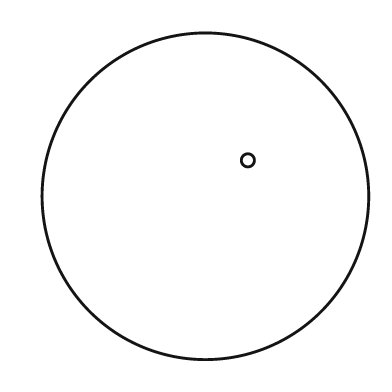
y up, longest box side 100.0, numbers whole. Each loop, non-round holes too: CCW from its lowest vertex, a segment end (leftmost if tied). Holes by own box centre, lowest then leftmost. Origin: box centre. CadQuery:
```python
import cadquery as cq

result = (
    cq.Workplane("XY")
    .moveTo(0.0, 0.0)
    .circle(50.0)
    .moveTo(13.0, 11.0)
    .circle(2.0)
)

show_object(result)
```